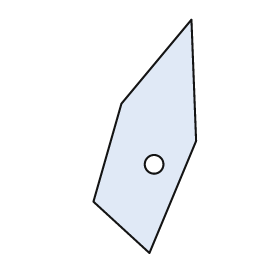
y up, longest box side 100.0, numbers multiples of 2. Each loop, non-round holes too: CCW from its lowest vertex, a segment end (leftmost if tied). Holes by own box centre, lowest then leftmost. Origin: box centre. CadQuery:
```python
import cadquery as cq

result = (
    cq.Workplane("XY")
    .moveTo(2.0, -50.0)
    .lineTo(22.0, -2.0)
    .lineTo(20.0, 50.0)
    .lineTo(-10.0, 14.0)
    .lineTo(-22.0, -28.0)
    .close()
    .moveTo(4.0, -12.0)
    .circle(4.0)
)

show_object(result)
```